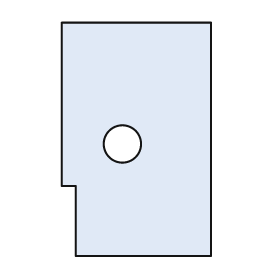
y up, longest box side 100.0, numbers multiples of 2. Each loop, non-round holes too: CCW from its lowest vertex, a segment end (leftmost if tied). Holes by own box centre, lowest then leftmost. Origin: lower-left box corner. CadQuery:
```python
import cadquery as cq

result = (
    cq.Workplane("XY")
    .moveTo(6.0, 0.0)
    .lineTo(64.0, 0.0)
    .lineTo(64.0, 100.0)
    .lineTo(0.0, 100.0)
    .lineTo(0.0, 30.0)
    .lineTo(6.0, 30.0)
    .close()
    .moveTo(26.0, 48.0)
    .circle(8.0)
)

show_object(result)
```